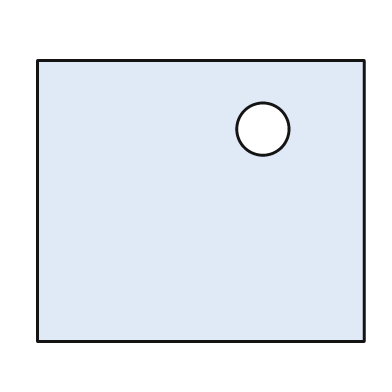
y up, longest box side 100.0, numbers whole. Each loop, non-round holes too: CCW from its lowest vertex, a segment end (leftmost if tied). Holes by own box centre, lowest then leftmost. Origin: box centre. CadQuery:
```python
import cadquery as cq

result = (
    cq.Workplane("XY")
    .moveTo(-50.0, -43.0)
    .lineTo(50.0, -43.0)
    .lineTo(50.0, 43.0)
    .lineTo(-50.0, 43.0)
    .close()
    .moveTo(19.0, 22.0)
    .circle(8.0)
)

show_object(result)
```